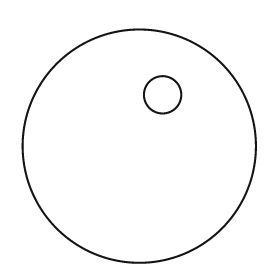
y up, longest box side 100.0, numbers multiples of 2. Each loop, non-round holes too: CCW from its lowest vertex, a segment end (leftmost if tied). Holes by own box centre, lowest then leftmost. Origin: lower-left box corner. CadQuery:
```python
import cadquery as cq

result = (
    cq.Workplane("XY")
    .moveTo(50.0, 50.0)
    .circle(50.0)
    .moveTo(60.0, 72.0)
    .circle(8.0)
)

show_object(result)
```